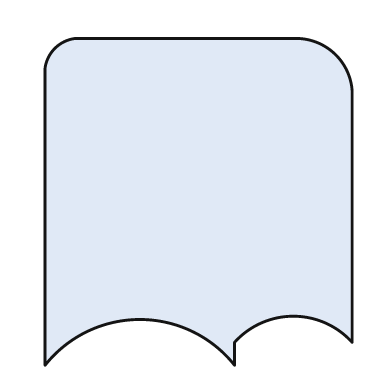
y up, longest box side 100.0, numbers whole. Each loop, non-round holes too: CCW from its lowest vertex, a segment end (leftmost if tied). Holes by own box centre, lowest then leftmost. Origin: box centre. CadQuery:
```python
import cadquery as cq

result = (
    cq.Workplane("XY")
    .moveTo(-47.0, -50.0)
    .threePointArc((-18.0, -36.0), (11.0, -50.0))
    .lineTo(11.0, -43.0)
    .threePointArc((29.0, -35.0), (47.0, -43.0))
    .lineTo(47.0, 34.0)
    .threePointArc((42.0, 45.0), (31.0, 50.0))
    .lineTo(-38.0, 50.0)
    .threePointArc((-44.0, 47.0), (-47.0, 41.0))
    .close()
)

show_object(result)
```